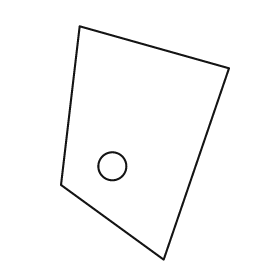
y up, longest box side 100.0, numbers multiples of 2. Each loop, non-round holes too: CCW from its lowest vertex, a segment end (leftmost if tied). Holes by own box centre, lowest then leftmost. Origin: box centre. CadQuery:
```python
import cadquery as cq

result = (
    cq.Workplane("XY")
    .moveTo(8.0, -50.0)
    .lineTo(36.0, 32.0)
    .lineTo(-28.0, 50.0)
    .lineTo(-36.0, -18.0)
    .close()
    .moveTo(-14.0, -10.0)
    .circle(6.0)
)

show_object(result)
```